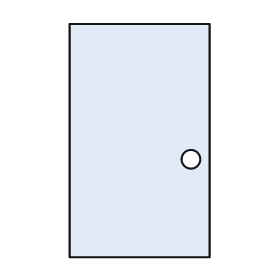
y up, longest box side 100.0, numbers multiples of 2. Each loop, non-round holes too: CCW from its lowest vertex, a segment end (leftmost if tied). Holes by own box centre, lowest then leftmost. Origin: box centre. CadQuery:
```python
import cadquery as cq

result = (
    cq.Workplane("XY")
    .moveTo(-30.0, -50.0)
    .lineTo(30.0, -50.0)
    .lineTo(30.0, 50.0)
    .lineTo(-30.0, 50.0)
    .close()
    .moveTo(22.0, -8.0)
    .circle(4.0)
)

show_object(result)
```